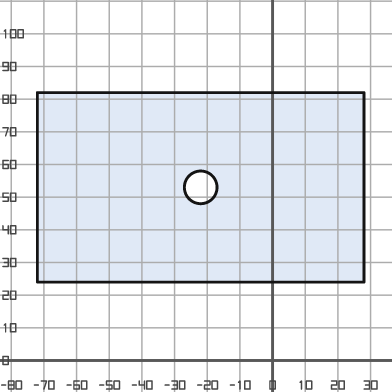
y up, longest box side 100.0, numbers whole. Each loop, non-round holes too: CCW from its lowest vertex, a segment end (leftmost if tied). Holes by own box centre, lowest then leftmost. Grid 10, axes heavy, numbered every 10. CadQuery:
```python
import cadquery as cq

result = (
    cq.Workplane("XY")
    .moveTo(-72.0, 24.0)
    .lineTo(28.0, 24.0)
    .lineTo(28.0, 82.0)
    .lineTo(-72.0, 82.0)
    .close()
    .moveTo(-22.0, 53.0)
    .circle(5.0)
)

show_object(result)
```